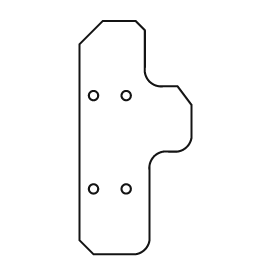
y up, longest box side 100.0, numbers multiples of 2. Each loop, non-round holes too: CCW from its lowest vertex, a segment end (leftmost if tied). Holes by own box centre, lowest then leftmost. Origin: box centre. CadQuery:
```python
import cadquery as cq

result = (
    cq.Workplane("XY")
    .moveTo(-18.0, -50.0)
    .lineTo(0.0, -50.0)
    .threePointArc((4.0, -48.0), (6.0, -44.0))
    .lineTo(6.0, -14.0)
    .threePointArc((8.0, -8.0), (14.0, -6.0))
    .lineTo(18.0, -6.0)
    .threePointArc((22.0, -4.0), (24.0, 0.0))
    .lineTo(24.0, 14.0)
    .lineTo(18.0, 22.0)
    .lineTo(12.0, 22.0)
    .threePointArc((6.0, 24.0), (4.0, 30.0))
    .lineTo(4.0, 46.0)
    .lineTo(0.0, 50.0)
    .lineTo(-14.0, 50.0)
    .lineTo(-24.0, 40.0)
    .lineTo(-24.0, -44.0)
    .close()
    .moveTo(-18.0, -22.0)
    .circle(2.0)
    .moveTo(-4.0, -22.0)
    .circle(2.0)
    .moveTo(-18.0, 18.0)
    .circle(2.0)
    .moveTo(-4.0, 18.0)
    .circle(2.0)
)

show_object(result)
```